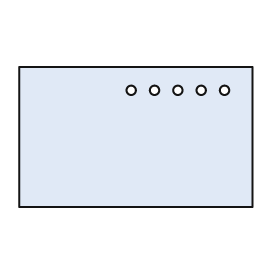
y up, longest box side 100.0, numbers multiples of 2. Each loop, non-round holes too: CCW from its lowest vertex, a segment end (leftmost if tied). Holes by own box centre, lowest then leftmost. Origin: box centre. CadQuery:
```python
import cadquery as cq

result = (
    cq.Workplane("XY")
    .moveTo(-50.0, -30.0)
    .lineTo(50.0, -30.0)
    .lineTo(50.0, 30.0)
    .lineTo(-50.0, 30.0)
    .close()
    .moveTo(-2.0, 20.0)
    .circle(2.0)
    .moveTo(8.0, 20.0)
    .circle(2.0)
    .moveTo(18.0, 20.0)
    .circle(2.0)
    .moveTo(28.0, 20.0)
    .circle(2.0)
    .moveTo(38.0, 20.0)
    .circle(2.0)
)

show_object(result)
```